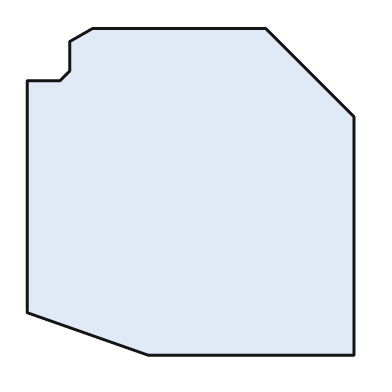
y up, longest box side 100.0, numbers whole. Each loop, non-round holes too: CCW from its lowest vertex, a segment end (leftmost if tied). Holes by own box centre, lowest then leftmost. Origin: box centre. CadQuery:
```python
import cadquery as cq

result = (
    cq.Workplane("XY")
    .moveTo(-13.0, -50.0)
    .lineTo(50.0, -50.0)
    .lineTo(50.0, 23.0)
    .lineTo(23.0, 50.0)
    .lineTo(-30.0, 50.0)
    .lineTo(-37.0, 46.0)
    .lineTo(-37.0, 37.0)
    .lineTo(-40.0, 34.0)
    .lineTo(-50.0, 34.0)
    .lineTo(-50.0, -37.0)
    .close()
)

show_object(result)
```